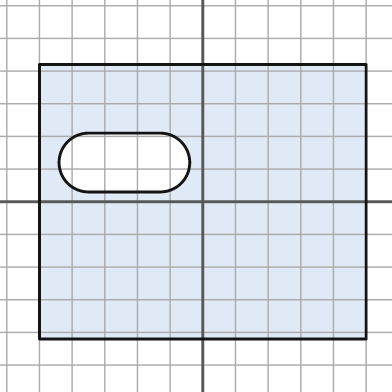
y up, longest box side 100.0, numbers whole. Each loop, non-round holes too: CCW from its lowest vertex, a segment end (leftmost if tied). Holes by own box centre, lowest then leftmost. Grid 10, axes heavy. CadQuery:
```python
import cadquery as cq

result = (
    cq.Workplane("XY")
    .moveTo(-50.0, -42.0)
    .lineTo(50.0, -42.0)
    .lineTo(50.0, 42.0)
    .lineTo(-50.0, 42.0)
    .close()
    .moveTo(-35.0, 3.0)
    .lineTo(-13.0, 3.0)
    .threePointArc((-4.0, 12.0), (-13.0, 21.0))
    .lineTo(-35.0, 21.0)
    .threePointArc((-44.0, 12.0), (-35.0, 3.0))
    .close()
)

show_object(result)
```